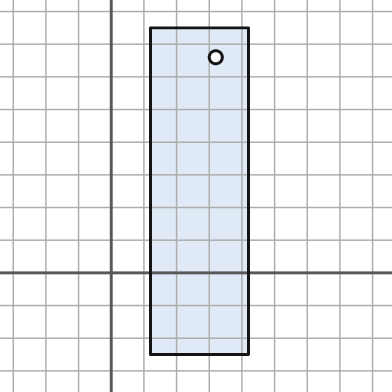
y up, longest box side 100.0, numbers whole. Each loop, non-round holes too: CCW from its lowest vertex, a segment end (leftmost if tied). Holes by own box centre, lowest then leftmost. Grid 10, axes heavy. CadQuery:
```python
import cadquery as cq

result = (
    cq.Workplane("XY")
    .moveTo(12.0, -25.0)
    .lineTo(42.0, -25.0)
    .lineTo(42.0, 75.0)
    .lineTo(12.0, 75.0)
    .close()
    .moveTo(32.0, 66.0)
    .circle(2.0)
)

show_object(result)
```